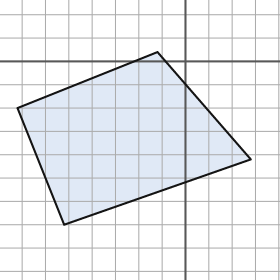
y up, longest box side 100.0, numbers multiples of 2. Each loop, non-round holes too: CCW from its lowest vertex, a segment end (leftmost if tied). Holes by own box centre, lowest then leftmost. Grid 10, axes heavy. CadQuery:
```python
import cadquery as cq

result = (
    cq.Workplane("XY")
    .moveTo(-52.0, -70.0)
    .lineTo(28.0, -42.0)
    .lineTo(-12.0, 4.0)
    .lineTo(-72.0, -20.0)
    .close()
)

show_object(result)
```